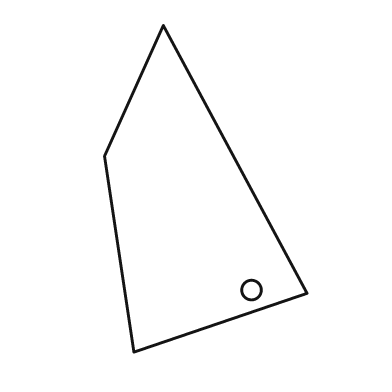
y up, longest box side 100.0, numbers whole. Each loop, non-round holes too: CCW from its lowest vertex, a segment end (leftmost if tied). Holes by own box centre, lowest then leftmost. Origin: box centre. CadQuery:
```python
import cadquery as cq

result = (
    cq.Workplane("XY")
    .moveTo(-22.0, -50.0)
    .lineTo(31.0, -32.0)
    .lineTo(-13.0, 50.0)
    .lineTo(-31.0, 10.0)
    .close()
    .moveTo(14.0, -31.0)
    .circle(3.0)
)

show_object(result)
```